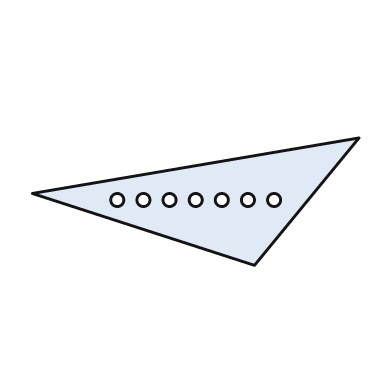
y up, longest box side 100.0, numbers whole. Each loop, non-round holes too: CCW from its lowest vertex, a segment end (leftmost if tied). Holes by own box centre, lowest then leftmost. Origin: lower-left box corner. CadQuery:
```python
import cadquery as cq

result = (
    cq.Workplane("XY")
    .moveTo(68.0, 0.0)
    .lineTo(100.0, 39.0)
    .lineTo(0.0, 22.0)
    .close()
    .moveTo(26.0, 20.0)
    .circle(2.0)
    .moveTo(34.0, 20.0)
    .circle(2.0)
    .moveTo(42.0, 20.0)
    .circle(2.0)
    .moveTo(50.0, 20.0)
    .circle(2.0)
    .moveTo(58.0, 20.0)
    .circle(2.0)
    .moveTo(66.0, 20.0)
    .circle(2.0)
    .moveTo(74.0, 20.0)
    .circle(2.0)
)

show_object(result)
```